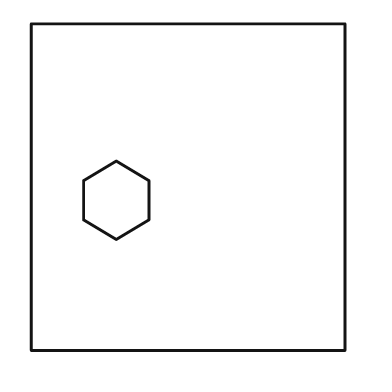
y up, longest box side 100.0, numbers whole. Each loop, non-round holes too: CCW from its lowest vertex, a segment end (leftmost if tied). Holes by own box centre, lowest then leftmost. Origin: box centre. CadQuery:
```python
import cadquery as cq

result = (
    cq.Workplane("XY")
    .moveTo(-48.0, -50.0)
    .lineTo(48.0, -50.0)
    .lineTo(48.0, 50.0)
    .lineTo(-48.0, 50.0)
    .close()
    .moveTo(-22.0, -16.0)
    .lineTo(-12.0, -10.0)
    .lineTo(-12.0, 2.0)
    .lineTo(-22.0, 8.0)
    .lineTo(-32.0, 2.0)
    .lineTo(-32.0, -10.0)
    .close()
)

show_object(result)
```